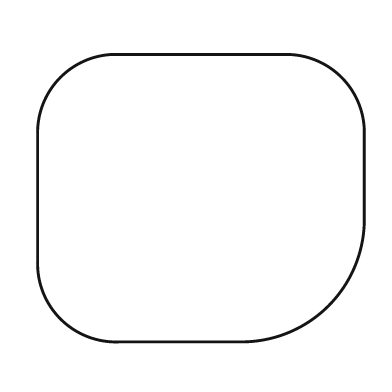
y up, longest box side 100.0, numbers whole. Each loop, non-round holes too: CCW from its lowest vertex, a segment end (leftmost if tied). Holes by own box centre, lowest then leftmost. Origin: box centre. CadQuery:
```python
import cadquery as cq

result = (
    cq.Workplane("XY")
    .moveTo(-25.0, -44.0)
    .lineTo(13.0, -44.0)
    .threePointArc((39.0, -33.0), (50.0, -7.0))
    .lineTo(50.0, 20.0)
    .threePointArc((43.0, 37.0), (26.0, 44.0))
    .lineTo(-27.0, 44.0)
    .threePointArc((-43.0, 37.0), (-50.0, 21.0))
    .lineTo(-50.0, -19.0)
    .threePointArc((-43.0, -37.0), (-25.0, -44.0))
    .close()
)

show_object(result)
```